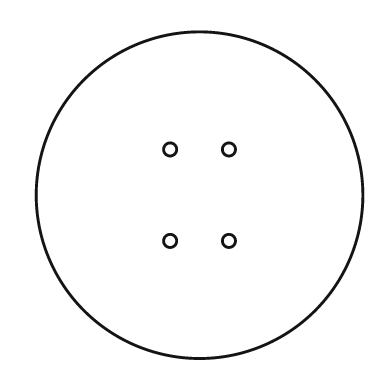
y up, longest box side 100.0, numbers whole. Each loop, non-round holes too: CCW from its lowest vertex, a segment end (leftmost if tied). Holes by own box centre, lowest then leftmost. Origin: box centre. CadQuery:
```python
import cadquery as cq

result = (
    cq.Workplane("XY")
    .moveTo(0.0, 0.0)
    .circle(50.0)
    .moveTo(-9.0, -14.0)
    .circle(2.0)
    .moveTo(9.0, -14.0)
    .circle(2.0)
    .moveTo(-9.0, 14.0)
    .circle(2.0)
    .moveTo(9.0, 14.0)
    .circle(2.0)
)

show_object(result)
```